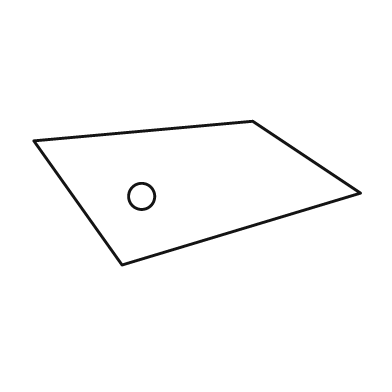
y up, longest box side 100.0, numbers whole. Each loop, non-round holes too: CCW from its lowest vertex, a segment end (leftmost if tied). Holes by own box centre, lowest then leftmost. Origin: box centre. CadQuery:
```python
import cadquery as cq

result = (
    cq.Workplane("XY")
    .moveTo(-23.0, -22.0)
    .lineTo(50.0, 0.0)
    .lineTo(17.0, 22.0)
    .lineTo(-50.0, 16.0)
    .close()
    .moveTo(-17.0, -1.0)
    .circle(4.0)
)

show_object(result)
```